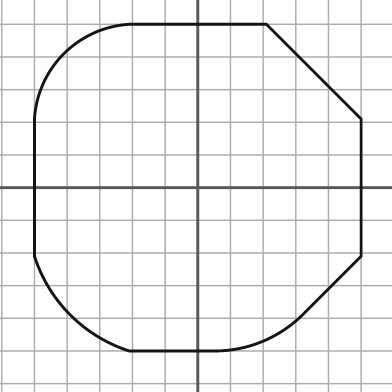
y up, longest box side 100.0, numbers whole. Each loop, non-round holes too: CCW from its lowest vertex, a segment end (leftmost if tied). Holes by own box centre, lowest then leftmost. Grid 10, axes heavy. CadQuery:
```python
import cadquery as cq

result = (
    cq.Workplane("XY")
    .moveTo(-21.0, -50.0)
    .lineTo(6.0, -50.0)
    .threePointArc((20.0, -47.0), (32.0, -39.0))
    .lineTo(50.0, -21.0)
    .lineTo(50.0, 21.0)
    .lineTo(21.0, 50.0)
    .lineTo(-21.0, 50.0)
    .threePointArc((-41.0, 41.0), (-50.0, 21.0))
    .lineTo(-50.0, -21.0)
    .threePointArc((-39.0, -39.0), (-21.0, -50.0))
    .close()
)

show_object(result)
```